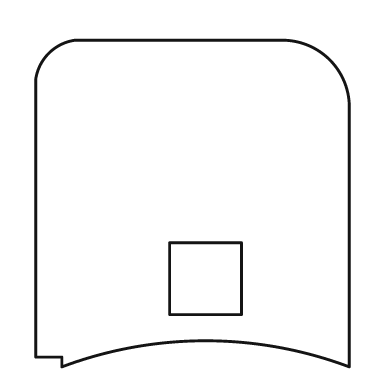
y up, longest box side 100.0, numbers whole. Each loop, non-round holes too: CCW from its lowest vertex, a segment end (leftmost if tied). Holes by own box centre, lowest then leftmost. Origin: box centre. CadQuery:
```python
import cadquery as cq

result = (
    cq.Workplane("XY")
    .moveTo(-40.0, -50.0)
    .threePointArc((4.0, -42.0), (48.0, -50.0))
    .lineTo(48.0, 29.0)
    .threePointArc((42.0, 44.0), (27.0, 50.0))
    .lineTo(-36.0, 50.0)
    .threePointArc((-44.0, 46.0), (-48.0, 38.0))
    .lineTo(-48.0, -47.0)
    .lineTo(-40.0, -47.0)
    .close()
    .moveTo(-7.0, -34.0)
    .lineTo(15.0, -34.0)
    .lineTo(15.0, -12.0)
    .lineTo(-7.0, -12.0)
    .close()
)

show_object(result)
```